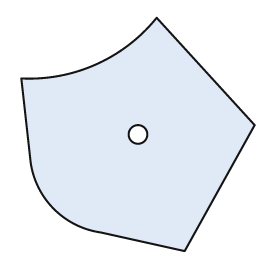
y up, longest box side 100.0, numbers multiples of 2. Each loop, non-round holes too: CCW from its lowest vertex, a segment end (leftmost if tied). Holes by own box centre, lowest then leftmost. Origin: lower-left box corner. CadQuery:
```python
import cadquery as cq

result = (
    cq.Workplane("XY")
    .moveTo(70.0, 0.0)
    .lineTo(100.0, 54.0)
    .lineTo(58.0, 100.0)
    .threePointArc((32.0, 80.0), (0.0, 74.0))
    .lineTo(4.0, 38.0)
    .threePointArc((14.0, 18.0), (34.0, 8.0))
    .close()
    .moveTo(50.0, 50.0)
    .circle(4.0)
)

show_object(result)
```